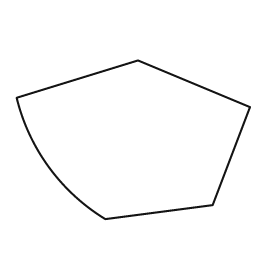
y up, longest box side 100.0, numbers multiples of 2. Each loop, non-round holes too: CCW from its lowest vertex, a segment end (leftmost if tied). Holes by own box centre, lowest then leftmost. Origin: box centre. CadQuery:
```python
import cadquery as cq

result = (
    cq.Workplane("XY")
    .moveTo(-12.0, -34.0)
    .lineTo(34.0, -28.0)
    .lineTo(50.0, 14.0)
    .lineTo(2.0, 34.0)
    .lineTo(-50.0, 18.0)
    .threePointArc((-36.0, -12.0), (-12.0, -34.0))
    .close()
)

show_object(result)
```